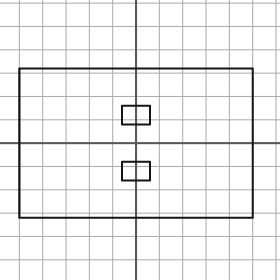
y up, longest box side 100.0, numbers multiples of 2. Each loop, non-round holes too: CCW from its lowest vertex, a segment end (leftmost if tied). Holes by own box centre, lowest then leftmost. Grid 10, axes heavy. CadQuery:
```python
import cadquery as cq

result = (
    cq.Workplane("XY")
    .moveTo(-50.0, -32.0)
    .lineTo(50.0, -32.0)
    .lineTo(50.0, 32.0)
    .lineTo(-50.0, 32.0)
    .close()
    .moveTo(-6.0, -16.0)
    .lineTo(6.0, -16.0)
    .lineTo(6.0, -8.0)
    .lineTo(-6.0, -8.0)
    .close()
    .moveTo(-6.0, 8.0)
    .lineTo(6.0, 8.0)
    .lineTo(6.0, 16.0)
    .lineTo(-6.0, 16.0)
    .close()
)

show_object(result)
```